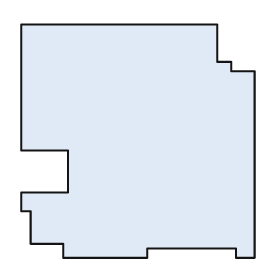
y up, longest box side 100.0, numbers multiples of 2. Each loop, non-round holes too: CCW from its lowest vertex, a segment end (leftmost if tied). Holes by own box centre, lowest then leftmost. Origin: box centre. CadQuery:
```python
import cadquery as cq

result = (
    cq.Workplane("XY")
    .moveTo(-32.0, -50.0)
    .lineTo(4.0, -50.0)
    .lineTo(4.0, -46.0)
    .lineTo(42.0, -46.0)
    .lineTo(42.0, -50.0)
    .lineTo(50.0, -50.0)
    .lineTo(50.0, 30.0)
    .lineTo(40.0, 30.0)
    .lineTo(40.0, 34.0)
    .lineTo(34.0, 34.0)
    .lineTo(34.0, 50.0)
    .lineTo(-50.0, 50.0)
    .lineTo(-50.0, -4.0)
    .lineTo(-30.0, -4.0)
    .lineTo(-30.0, -22.0)
    .lineTo(-50.0, -22.0)
    .lineTo(-50.0, -30.0)
    .lineTo(-46.0, -30.0)
    .lineTo(-46.0, -44.0)
    .lineTo(-32.0, -44.0)
    .close()
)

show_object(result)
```